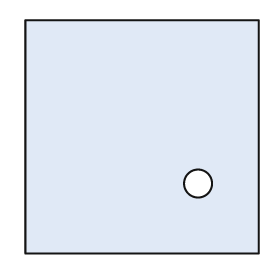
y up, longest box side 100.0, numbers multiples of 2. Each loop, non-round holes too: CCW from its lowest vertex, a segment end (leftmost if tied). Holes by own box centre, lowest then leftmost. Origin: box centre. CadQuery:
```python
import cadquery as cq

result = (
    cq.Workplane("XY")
    .moveTo(-50.0, -50.0)
    .lineTo(50.0, -50.0)
    .lineTo(50.0, 50.0)
    .lineTo(-50.0, 50.0)
    .close()
    .moveTo(24.0, -20.0)
    .circle(6.0)
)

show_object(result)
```